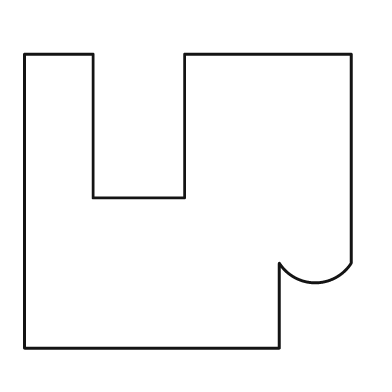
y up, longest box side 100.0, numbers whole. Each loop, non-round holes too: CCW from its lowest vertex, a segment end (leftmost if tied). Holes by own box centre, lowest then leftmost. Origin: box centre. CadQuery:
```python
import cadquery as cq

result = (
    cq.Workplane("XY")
    .moveTo(-50.0, -45.0)
    .lineTo(28.0, -45.0)
    .lineTo(28.0, -19.0)
    .threePointArc((39.0, -25.0), (50.0, -19.0))
    .lineTo(50.0, 45.0)
    .lineTo(-1.0, 45.0)
    .lineTo(-1.0, 1.0)
    .lineTo(-29.0, 1.0)
    .lineTo(-29.0, 45.0)
    .lineTo(-50.0, 45.0)
    .close()
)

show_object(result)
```